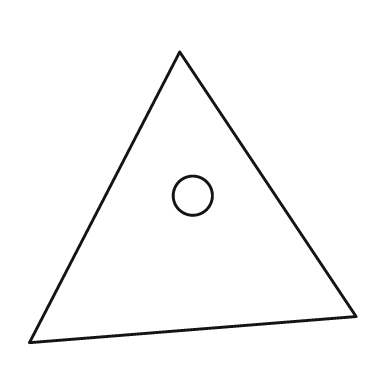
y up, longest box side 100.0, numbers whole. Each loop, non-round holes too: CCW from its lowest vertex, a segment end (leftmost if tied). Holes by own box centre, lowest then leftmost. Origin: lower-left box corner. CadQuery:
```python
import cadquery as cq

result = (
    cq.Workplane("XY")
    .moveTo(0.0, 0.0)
    .lineTo(100.0, 8.0)
    .lineTo(46.0, 89.0)
    .close()
    .moveTo(50.0, 45.0)
    .circle(6.0)
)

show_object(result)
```